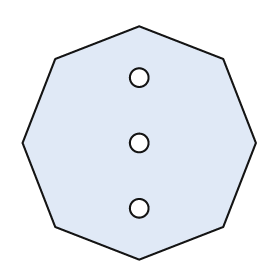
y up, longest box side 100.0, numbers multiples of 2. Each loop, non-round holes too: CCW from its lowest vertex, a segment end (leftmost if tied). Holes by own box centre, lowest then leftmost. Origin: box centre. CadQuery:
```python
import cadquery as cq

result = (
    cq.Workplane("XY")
    .moveTo(0.0, -50.0)
    .lineTo(36.0, -36.0)
    .lineTo(50.0, 0.0)
    .lineTo(36.0, 36.0)
    .lineTo(0.0, 50.0)
    .lineTo(-36.0, 36.0)
    .lineTo(-50.0, 0.0)
    .lineTo(-36.0, -36.0)
    .close()
    .moveTo(0.0, -28.0)
    .circle(4.0)
    .moveTo(0.0, 0.0)
    .circle(4.0)
    .moveTo(0.0, 28.0)
    .circle(4.0)
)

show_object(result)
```